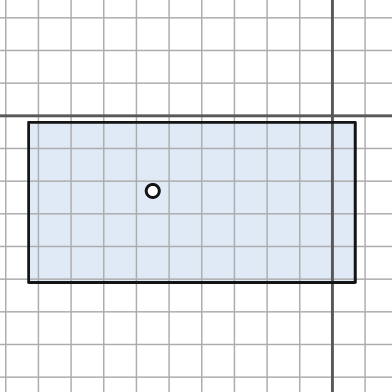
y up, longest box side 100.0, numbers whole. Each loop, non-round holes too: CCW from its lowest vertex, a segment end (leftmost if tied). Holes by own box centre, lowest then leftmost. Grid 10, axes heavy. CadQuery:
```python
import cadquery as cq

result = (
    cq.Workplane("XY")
    .moveTo(-93.0, -51.0)
    .lineTo(7.0, -51.0)
    .lineTo(7.0, -2.0)
    .lineTo(-93.0, -2.0)
    .close()
    .moveTo(-55.0, -23.0)
    .circle(2.0)
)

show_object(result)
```